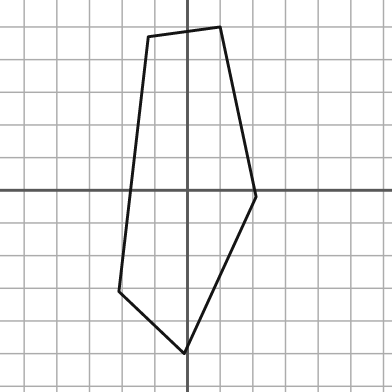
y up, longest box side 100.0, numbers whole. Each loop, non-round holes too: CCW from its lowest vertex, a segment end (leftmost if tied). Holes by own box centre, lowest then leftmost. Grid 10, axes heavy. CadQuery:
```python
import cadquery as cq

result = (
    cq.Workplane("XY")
    .moveTo(-1.0, -50.0)
    .lineTo(21.0, -2.0)
    .lineTo(10.0, 50.0)
    .lineTo(-12.0, 47.0)
    .lineTo(-21.0, -31.0)
    .close()
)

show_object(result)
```